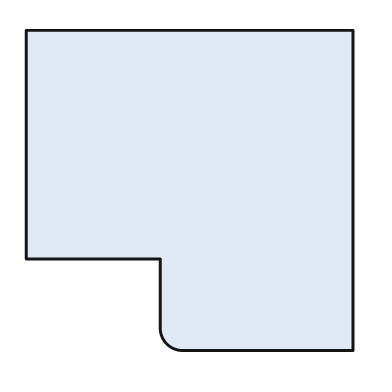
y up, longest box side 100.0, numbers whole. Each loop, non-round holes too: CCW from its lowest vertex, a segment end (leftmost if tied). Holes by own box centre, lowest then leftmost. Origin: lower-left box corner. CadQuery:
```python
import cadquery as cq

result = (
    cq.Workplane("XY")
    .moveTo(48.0, 0.0)
    .lineTo(100.0, 0.0)
    .lineTo(100.0, 98.0)
    .lineTo(0.0, 98.0)
    .lineTo(0.0, 28.0)
    .lineTo(41.0, 28.0)
    .lineTo(41.0, 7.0)
    .threePointArc((43.0, 2.0), (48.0, 0.0))
    .close()
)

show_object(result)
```